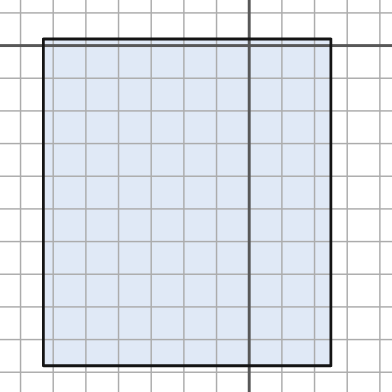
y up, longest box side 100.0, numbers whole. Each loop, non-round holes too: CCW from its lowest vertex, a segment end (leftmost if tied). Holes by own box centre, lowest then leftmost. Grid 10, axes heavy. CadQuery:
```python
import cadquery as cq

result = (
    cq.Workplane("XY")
    .moveTo(-63.0, -98.0)
    .lineTo(25.0, -98.0)
    .lineTo(25.0, 2.0)
    .lineTo(-63.0, 2.0)
    .close()
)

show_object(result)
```